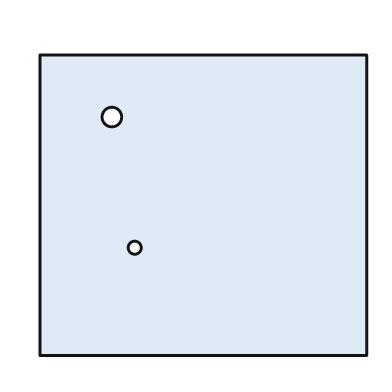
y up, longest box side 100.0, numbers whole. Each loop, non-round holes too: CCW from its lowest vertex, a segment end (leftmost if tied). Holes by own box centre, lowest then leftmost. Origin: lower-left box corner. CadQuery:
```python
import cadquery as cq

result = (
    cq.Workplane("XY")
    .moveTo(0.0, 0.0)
    .lineTo(100.0, 0.0)
    .lineTo(100.0, 92.0)
    .lineTo(0.0, 92.0)
    .close()
    .moveTo(29.0, 33.0)
    .circle(2.0)
    .moveTo(22.0, 73.0)
    .circle(3.0)
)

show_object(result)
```